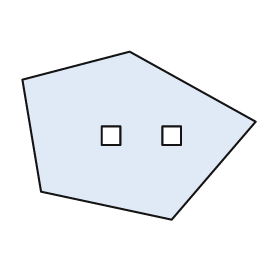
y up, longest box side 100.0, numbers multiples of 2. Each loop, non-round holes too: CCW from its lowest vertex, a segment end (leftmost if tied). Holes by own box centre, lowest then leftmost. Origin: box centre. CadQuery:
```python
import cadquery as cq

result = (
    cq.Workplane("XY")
    .moveTo(14.0, -36.0)
    .lineTo(50.0, 6.0)
    .lineTo(-4.0, 36.0)
    .lineTo(-50.0, 24.0)
    .lineTo(-42.0, -24.0)
    .close()
    .moveTo(-16.0, -4.0)
    .lineTo(-8.0, -4.0)
    .lineTo(-8.0, 4.0)
    .lineTo(-16.0, 4.0)
    .close()
    .moveTo(10.0, -4.0)
    .lineTo(18.0, -4.0)
    .lineTo(18.0, 4.0)
    .lineTo(10.0, 4.0)
    .close()
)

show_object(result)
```